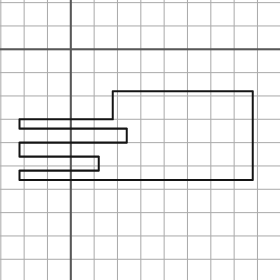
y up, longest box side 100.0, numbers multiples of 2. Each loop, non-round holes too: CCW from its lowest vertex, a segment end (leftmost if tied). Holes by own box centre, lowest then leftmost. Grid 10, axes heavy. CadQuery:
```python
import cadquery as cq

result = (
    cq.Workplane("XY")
    .moveTo(-22.0, -56.0)
    .lineTo(78.0, -56.0)
    .lineTo(78.0, -18.0)
    .lineTo(18.0, -18.0)
    .lineTo(18.0, -30.0)
    .lineTo(-22.0, -30.0)
    .lineTo(-22.0, -34.0)
    .lineTo(24.0, -34.0)
    .lineTo(24.0, -40.0)
    .lineTo(-22.0, -40.0)
    .lineTo(-22.0, -46.0)
    .lineTo(12.0, -46.0)
    .lineTo(12.0, -52.0)
    .lineTo(-22.0, -52.0)
    .close()
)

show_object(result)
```